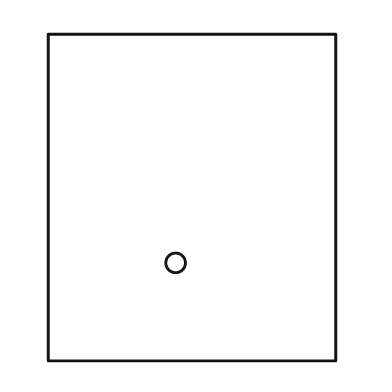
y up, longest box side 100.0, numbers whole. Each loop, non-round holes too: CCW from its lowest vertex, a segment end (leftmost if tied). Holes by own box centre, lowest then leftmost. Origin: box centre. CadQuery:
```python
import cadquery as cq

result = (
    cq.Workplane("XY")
    .moveTo(-44.0, -50.0)
    .lineTo(44.0, -50.0)
    .lineTo(44.0, 50.0)
    .lineTo(-44.0, 50.0)
    .close()
    .moveTo(-5.0, -20.0)
    .circle(3.0)
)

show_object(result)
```